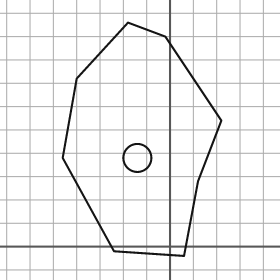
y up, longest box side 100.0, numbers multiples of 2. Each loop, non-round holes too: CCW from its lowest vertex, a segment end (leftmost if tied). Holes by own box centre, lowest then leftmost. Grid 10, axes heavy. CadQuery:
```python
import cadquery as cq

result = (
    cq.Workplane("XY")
    .moveTo(6.0, -4.0)
    .lineTo(12.0, 28.0)
    .lineTo(22.0, 54.0)
    .lineTo(-2.0, 90.0)
    .lineTo(-18.0, 96.0)
    .lineTo(-40.0, 72.0)
    .lineTo(-46.0, 38.0)
    .lineTo(-24.0, -2.0)
    .close()
    .moveTo(-14.0, 38.0)
    .circle(6.0)
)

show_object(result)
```